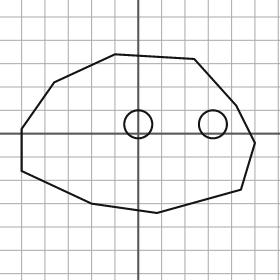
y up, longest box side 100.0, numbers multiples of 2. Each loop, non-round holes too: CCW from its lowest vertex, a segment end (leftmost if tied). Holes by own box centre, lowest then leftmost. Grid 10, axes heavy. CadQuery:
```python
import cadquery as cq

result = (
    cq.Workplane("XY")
    .moveTo(8.0, -34.0)
    .lineTo(44.0, -24.0)
    .lineTo(50.0, -4.0)
    .lineTo(42.0, 12.0)
    .lineTo(24.0, 32.0)
    .lineTo(-10.0, 34.0)
    .lineTo(-36.0, 22.0)
    .lineTo(-50.0, 2.0)
    .lineTo(-50.0, -16.0)
    .lineTo(-20.0, -30.0)
    .close()
    .moveTo(0.0, 4.0)
    .circle(6.0)
    .moveTo(32.0, 4.0)
    .circle(6.0)
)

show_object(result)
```